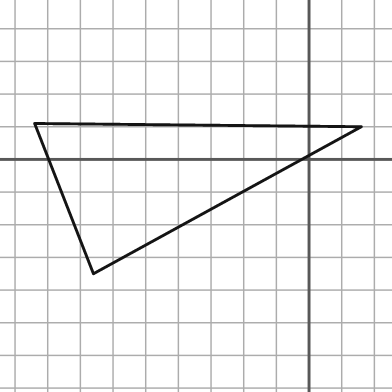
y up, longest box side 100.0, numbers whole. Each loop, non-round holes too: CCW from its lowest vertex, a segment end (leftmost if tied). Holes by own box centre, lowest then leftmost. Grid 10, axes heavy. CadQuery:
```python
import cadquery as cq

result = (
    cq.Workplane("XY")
    .moveTo(-66.0, -35.0)
    .lineTo(16.0, 10.0)
    .lineTo(-84.0, 11.0)
    .close()
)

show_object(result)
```